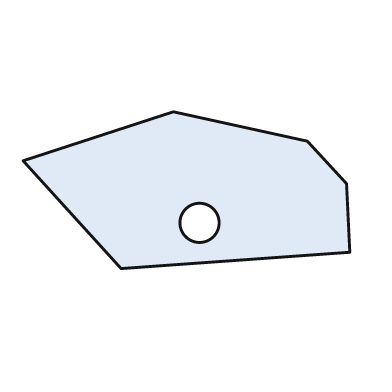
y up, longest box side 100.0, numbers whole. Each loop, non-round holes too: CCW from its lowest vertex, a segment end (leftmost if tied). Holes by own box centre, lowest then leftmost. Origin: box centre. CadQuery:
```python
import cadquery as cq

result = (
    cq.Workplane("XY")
    .moveTo(-20.0, -24.0)
    .lineTo(50.0, -19.0)
    .lineTo(49.0, 2.0)
    .lineTo(37.0, 15.0)
    .lineTo(-4.0, 24.0)
    .lineTo(-50.0, 9.0)
    .close()
    .moveTo(4.0, -10.0)
    .circle(6.0)
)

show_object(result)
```